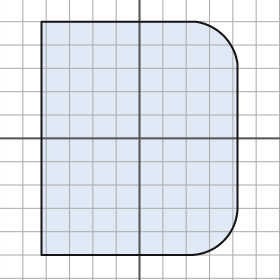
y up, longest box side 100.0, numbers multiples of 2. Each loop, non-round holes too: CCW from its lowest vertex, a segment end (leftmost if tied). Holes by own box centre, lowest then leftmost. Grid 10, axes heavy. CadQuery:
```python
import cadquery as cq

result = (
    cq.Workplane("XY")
    .moveTo(-42.0, -50.0)
    .lineTo(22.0, -50.0)
    .threePointArc((36.0, -44.0), (42.0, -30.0))
    .lineTo(42.0, 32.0)
    .threePointArc((36.0, 44.0), (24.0, 50.0))
    .lineTo(-42.0, 50.0)
    .close()
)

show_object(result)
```